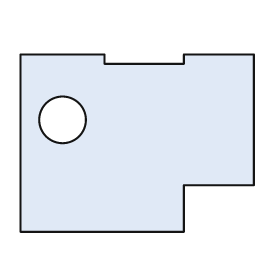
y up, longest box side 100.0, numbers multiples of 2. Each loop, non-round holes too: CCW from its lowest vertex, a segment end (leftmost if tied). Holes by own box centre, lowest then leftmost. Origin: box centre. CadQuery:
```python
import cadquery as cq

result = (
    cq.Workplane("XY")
    .moveTo(-50.0, -38.0)
    .lineTo(20.0, -38.0)
    .lineTo(20.0, -18.0)
    .lineTo(50.0, -18.0)
    .lineTo(50.0, 38.0)
    .lineTo(20.0, 38.0)
    .lineTo(20.0, 34.0)
    .lineTo(-14.0, 34.0)
    .lineTo(-14.0, 38.0)
    .lineTo(-50.0, 38.0)
    .close()
    .moveTo(-32.0, 10.0)
    .circle(10.0)
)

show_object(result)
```